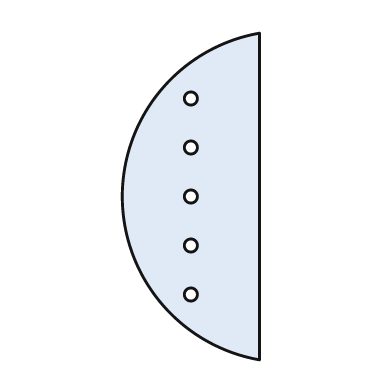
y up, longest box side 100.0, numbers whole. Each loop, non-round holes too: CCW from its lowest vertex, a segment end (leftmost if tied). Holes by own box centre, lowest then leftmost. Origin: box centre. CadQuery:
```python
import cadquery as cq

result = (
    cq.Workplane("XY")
    .moveTo(21.0, -50.0)
    .lineTo(21.0, 50.0)
    .threePointArc((-21.0, 0.0), (21.0, -50.0))
    .close()
    .moveTo(0.0, -30.0)
    .circle(2.0)
    .moveTo(0.0, -15.0)
    .circle(2.0)
    .moveTo(0.0, 0.0)
    .circle(2.0)
    .moveTo(0.0, 15.0)
    .circle(2.0)
    .moveTo(0.0, 30.0)
    .circle(2.0)
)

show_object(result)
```